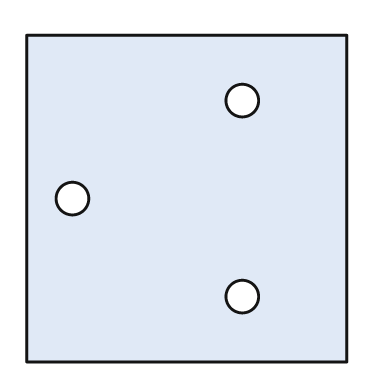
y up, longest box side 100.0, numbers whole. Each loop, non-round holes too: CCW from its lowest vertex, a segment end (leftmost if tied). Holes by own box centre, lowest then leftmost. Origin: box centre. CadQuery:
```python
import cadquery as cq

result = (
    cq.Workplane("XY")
    .moveTo(-49.0, -50.0)
    .lineTo(49.0, -50.0)
    .lineTo(49.0, 50.0)
    .lineTo(-49.0, 50.0)
    .close()
    .moveTo(17.0, -30.0)
    .circle(5.0)
    .moveTo(-35.0, 0.0)
    .circle(5.0)
    .moveTo(17.0, 30.0)
    .circle(5.0)
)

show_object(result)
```